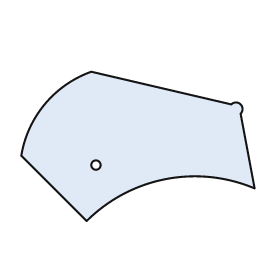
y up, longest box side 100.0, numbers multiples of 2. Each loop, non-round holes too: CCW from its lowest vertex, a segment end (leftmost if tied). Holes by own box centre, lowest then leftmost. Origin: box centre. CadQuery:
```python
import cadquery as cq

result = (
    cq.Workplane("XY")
    .moveTo(-22.0, -32.0)
    .threePointArc((12.0, -14.0), (50.0, -18.0))
    .lineTo(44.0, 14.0)
    .threePointArc((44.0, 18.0), (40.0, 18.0))
    .lineTo(-20.0, 32.0)
    .threePointArc((-40.0, 18.0), (-50.0, -4.0))
    .close()
    .moveTo(-18.0, -8.0)
    .circle(2.0)
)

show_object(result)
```